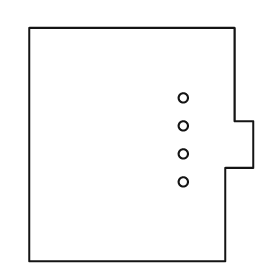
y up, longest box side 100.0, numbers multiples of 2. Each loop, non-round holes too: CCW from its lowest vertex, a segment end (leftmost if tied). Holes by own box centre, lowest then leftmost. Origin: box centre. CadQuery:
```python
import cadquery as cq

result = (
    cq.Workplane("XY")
    .moveTo(-48.0, -50.0)
    .lineTo(36.0, -50.0)
    .lineTo(36.0, -10.0)
    .lineTo(48.0, -10.0)
    .lineTo(48.0, 10.0)
    .lineTo(40.0, 10.0)
    .lineTo(40.0, 50.0)
    .lineTo(-48.0, 50.0)
    .close()
    .moveTo(18.0, -16.0)
    .circle(2.0)
    .moveTo(18.0, -4.0)
    .circle(2.0)
    .moveTo(18.0, 8.0)
    .circle(2.0)
    .moveTo(18.0, 20.0)
    .circle(2.0)
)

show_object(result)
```